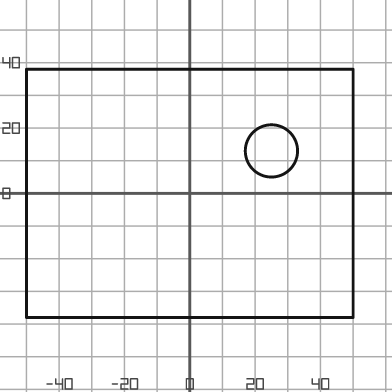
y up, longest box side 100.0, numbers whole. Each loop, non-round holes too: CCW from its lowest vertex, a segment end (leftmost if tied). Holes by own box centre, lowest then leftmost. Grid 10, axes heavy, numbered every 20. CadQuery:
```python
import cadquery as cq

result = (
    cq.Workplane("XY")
    .moveTo(-50.0, -38.0)
    .lineTo(50.0, -38.0)
    .lineTo(50.0, 38.0)
    .lineTo(-50.0, 38.0)
    .close()
    .moveTo(25.0, 13.0)
    .circle(8.0)
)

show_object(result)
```